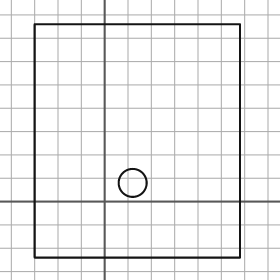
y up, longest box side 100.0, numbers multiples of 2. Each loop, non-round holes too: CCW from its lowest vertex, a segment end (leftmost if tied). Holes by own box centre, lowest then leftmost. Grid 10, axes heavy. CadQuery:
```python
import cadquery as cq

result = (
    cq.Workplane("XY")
    .moveTo(-30.0, -24.0)
    .lineTo(58.0, -24.0)
    .lineTo(58.0, 76.0)
    .lineTo(-30.0, 76.0)
    .close()
    .moveTo(12.0, 8.0)
    .circle(6.0)
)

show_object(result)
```